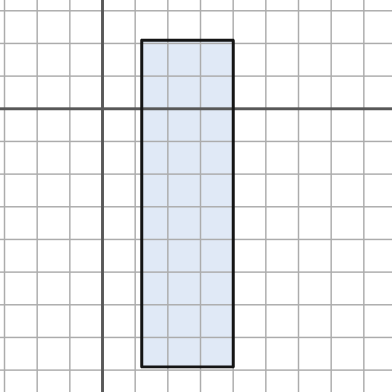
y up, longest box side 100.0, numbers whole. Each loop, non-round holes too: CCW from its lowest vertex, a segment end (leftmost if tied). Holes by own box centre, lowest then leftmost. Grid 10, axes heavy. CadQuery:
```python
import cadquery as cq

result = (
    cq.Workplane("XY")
    .moveTo(12.0, -79.0)
    .lineTo(40.0, -79.0)
    .lineTo(40.0, 21.0)
    .lineTo(12.0, 21.0)
    .close()
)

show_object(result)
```